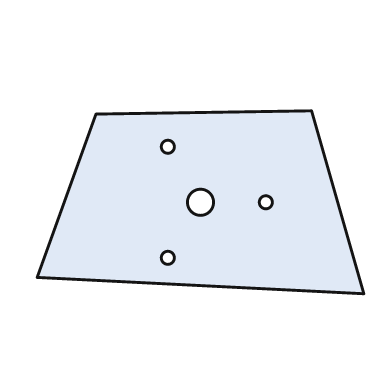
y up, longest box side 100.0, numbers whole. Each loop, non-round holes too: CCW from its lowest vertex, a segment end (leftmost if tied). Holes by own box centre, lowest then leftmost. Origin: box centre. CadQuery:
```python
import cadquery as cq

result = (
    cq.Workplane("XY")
    .moveTo(50.0, -28.0)
    .lineTo(34.0, 28.0)
    .lineTo(-32.0, 27.0)
    .lineTo(-50.0, -23.0)
    .close()
    .moveTo(-10.0, -17.0)
    .circle(2.0)
    .moveTo(0.0, 0.0)
    .circle(4.0)
    .moveTo(20.0, 0.0)
    .circle(2.0)
    .moveTo(-10.0, 17.0)
    .circle(2.0)
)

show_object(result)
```